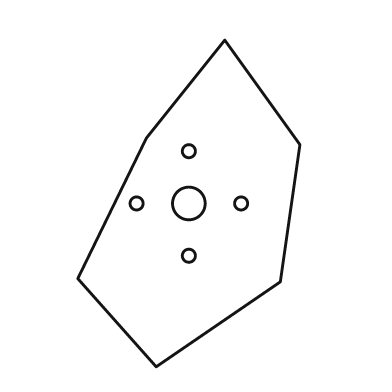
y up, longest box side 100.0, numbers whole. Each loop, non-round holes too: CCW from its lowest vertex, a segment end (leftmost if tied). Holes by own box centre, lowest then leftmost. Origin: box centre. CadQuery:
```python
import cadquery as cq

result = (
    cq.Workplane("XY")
    .moveTo(-10.0, -50.0)
    .lineTo(28.0, -24.0)
    .lineTo(34.0, 18.0)
    .lineTo(11.0, 50.0)
    .lineTo(-13.0, 20.0)
    .lineTo(-34.0, -23.0)
    .close()
    .moveTo(0.0, -16.0)
    .circle(2.0)
    .moveTo(-16.0, 0.0)
    .circle(2.0)
    .moveTo(0.0, 0.0)
    .circle(5.0)
    .moveTo(16.0, 0.0)
    .circle(2.0)
    .moveTo(0.0, 16.0)
    .circle(2.0)
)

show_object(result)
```